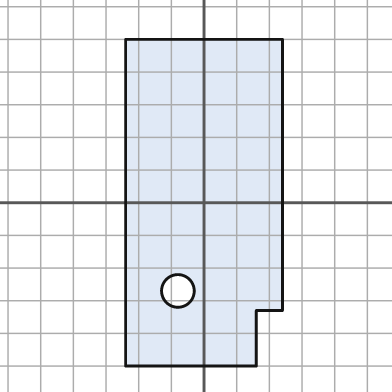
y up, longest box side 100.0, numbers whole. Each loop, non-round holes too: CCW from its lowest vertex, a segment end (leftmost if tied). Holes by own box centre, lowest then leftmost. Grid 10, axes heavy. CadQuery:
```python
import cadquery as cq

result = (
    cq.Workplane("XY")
    .moveTo(-24.0, -50.0)
    .lineTo(16.0, -50.0)
    .lineTo(16.0, -33.0)
    .lineTo(24.0, -33.0)
    .lineTo(24.0, 50.0)
    .lineTo(-24.0, 50.0)
    .close()
    .moveTo(-8.0, -27.0)
    .circle(5.0)
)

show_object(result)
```